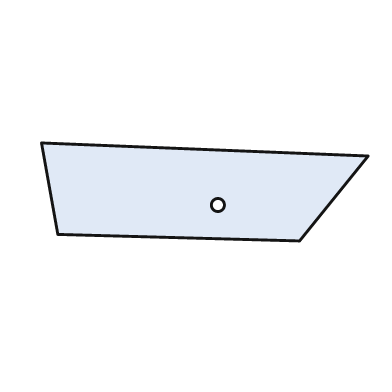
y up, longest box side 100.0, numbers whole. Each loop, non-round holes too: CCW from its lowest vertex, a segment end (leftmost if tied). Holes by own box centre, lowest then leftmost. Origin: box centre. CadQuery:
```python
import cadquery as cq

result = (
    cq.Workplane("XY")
    .moveTo(29.0, -15.0)
    .lineTo(50.0, 11.0)
    .lineTo(-50.0, 15.0)
    .lineTo(-45.0, -13.0)
    .close()
    .moveTo(4.0, -4.0)
    .circle(2.0)
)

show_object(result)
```